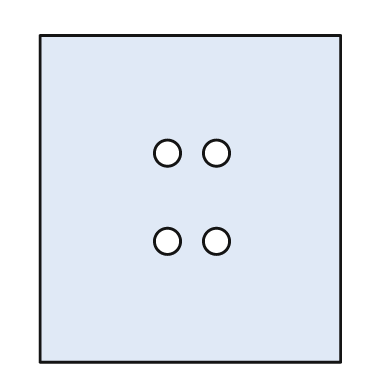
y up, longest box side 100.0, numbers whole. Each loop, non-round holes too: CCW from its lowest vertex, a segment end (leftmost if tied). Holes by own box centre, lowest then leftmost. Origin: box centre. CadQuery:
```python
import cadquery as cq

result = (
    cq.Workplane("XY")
    .moveTo(-46.0, -50.0)
    .lineTo(46.0, -50.0)
    .lineTo(46.0, 50.0)
    .lineTo(-46.0, 50.0)
    .close()
    .moveTo(-7.0, -13.0)
    .circle(4.0)
    .moveTo(8.0, -13.0)
    .circle(4.0)
    .moveTo(-7.0, 14.0)
    .circle(4.0)
    .moveTo(8.0, 14.0)
    .circle(4.0)
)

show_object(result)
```